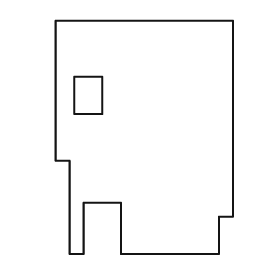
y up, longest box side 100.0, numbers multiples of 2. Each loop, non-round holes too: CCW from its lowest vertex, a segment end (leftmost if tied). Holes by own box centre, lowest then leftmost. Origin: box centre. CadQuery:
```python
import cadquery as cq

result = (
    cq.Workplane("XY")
    .moveTo(-32.0, -50.0)
    .lineTo(-26.0, -50.0)
    .lineTo(-26.0, -28.0)
    .lineTo(-10.0, -28.0)
    .lineTo(-10.0, -50.0)
    .lineTo(32.0, -50.0)
    .lineTo(32.0, -34.0)
    .lineTo(38.0, -34.0)
    .lineTo(38.0, 50.0)
    .lineTo(-38.0, 50.0)
    .lineTo(-38.0, -10.0)
    .lineTo(-32.0, -10.0)
    .close()
    .moveTo(-30.0, 10.0)
    .lineTo(-18.0, 10.0)
    .lineTo(-18.0, 26.0)
    .lineTo(-30.0, 26.0)
    .close()
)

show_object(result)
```